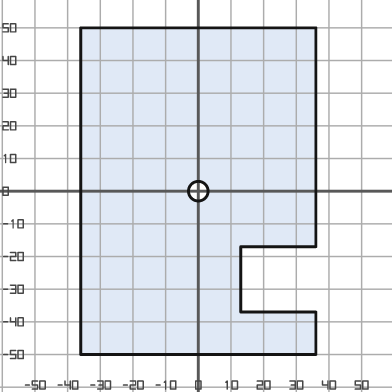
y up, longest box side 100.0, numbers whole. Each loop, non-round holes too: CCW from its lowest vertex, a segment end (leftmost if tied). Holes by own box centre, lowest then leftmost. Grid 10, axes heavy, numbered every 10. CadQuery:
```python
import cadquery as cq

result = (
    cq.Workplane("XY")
    .moveTo(-36.0, -50.0)
    .lineTo(36.0, -50.0)
    .lineTo(36.0, -37.0)
    .lineTo(13.0, -37.0)
    .lineTo(13.0, -17.0)
    .lineTo(36.0, -17.0)
    .lineTo(36.0, 50.0)
    .lineTo(-36.0, 50.0)
    .close()
    .moveTo(0.0, 0.0)
    .circle(3.0)
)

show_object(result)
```